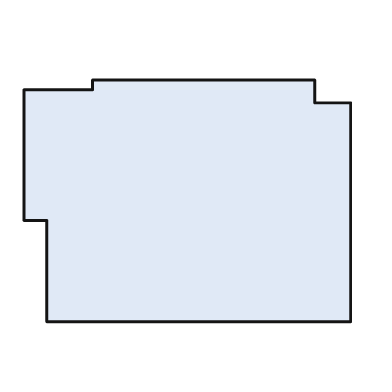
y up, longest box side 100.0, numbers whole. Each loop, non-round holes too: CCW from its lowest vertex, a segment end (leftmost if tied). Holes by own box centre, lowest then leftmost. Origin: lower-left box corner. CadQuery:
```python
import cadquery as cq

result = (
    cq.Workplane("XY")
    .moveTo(7.0, 0.0)
    .lineTo(100.0, 0.0)
    .lineTo(100.0, 67.0)
    .lineTo(89.0, 67.0)
    .lineTo(89.0, 74.0)
    .lineTo(21.0, 74.0)
    .lineTo(21.0, 71.0)
    .lineTo(0.0, 71.0)
    .lineTo(0.0, 31.0)
    .lineTo(7.0, 31.0)
    .close()
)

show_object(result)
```